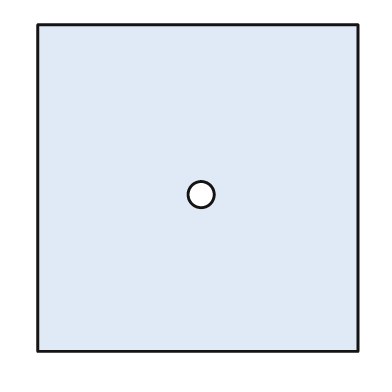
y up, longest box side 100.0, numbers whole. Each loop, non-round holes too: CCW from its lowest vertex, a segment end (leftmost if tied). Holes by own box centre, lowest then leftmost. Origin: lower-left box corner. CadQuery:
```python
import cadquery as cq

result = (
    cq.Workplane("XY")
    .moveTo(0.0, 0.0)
    .lineTo(98.0, 0.0)
    .lineTo(98.0, 100.0)
    .lineTo(0.0, 100.0)
    .close()
    .moveTo(50.0, 48.0)
    .circle(4.0)
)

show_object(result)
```